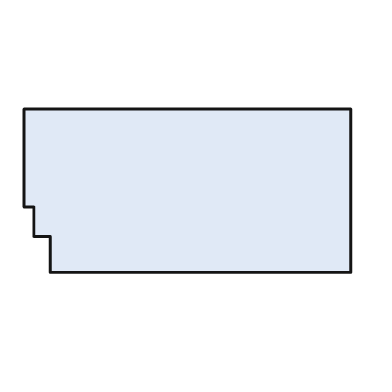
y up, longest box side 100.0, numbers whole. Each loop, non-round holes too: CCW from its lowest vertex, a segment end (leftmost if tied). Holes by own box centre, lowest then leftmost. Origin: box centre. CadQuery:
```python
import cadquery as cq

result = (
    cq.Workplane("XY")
    .moveTo(-42.0, -25.0)
    .lineTo(50.0, -25.0)
    .lineTo(50.0, 25.0)
    .lineTo(-50.0, 25.0)
    .lineTo(-50.0, -5.0)
    .lineTo(-47.0, -5.0)
    .lineTo(-47.0, -14.0)
    .lineTo(-42.0, -14.0)
    .close()
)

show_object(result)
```